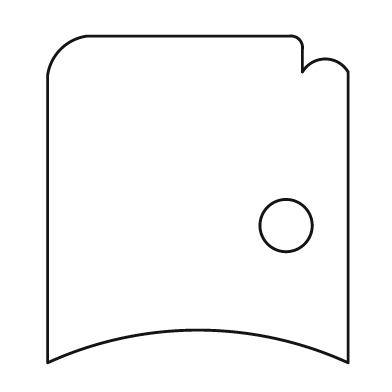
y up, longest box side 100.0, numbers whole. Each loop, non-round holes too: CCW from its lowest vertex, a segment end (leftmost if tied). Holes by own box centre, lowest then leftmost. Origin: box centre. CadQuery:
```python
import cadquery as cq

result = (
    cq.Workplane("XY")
    .moveTo(-46.0, -50.0)
    .threePointArc((0.0, -40.0), (46.0, -50.0))
    .lineTo(46.0, 39.0)
    .threePointArc((39.0, 43.0), (32.0, 39.0))
    .lineTo(32.0, 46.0)
    .threePointArc((31.0, 49.0), (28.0, 50.0))
    .lineTo(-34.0, 50.0)
    .threePointArc((-42.0, 46.0), (-46.0, 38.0))
    .close()
    .moveTo(27.0, -8.0)
    .circle(8.0)
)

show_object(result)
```